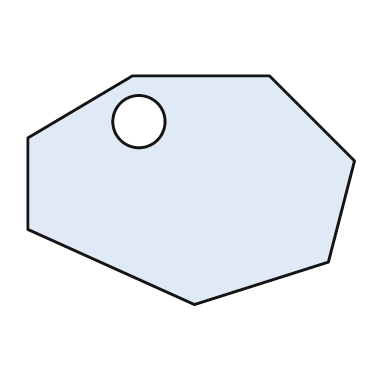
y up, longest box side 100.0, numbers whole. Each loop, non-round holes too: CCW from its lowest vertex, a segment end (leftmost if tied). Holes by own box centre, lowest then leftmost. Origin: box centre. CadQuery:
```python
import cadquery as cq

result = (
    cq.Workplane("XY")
    .moveTo(1.0, -35.0)
    .lineTo(42.0, -22.0)
    .lineTo(50.0, 9.0)
    .lineTo(24.0, 35.0)
    .lineTo(-18.0, 35.0)
    .lineTo(-50.0, 16.0)
    .lineTo(-50.0, -12.0)
    .close()
    .moveTo(-16.0, 21.0)
    .circle(8.0)
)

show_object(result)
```